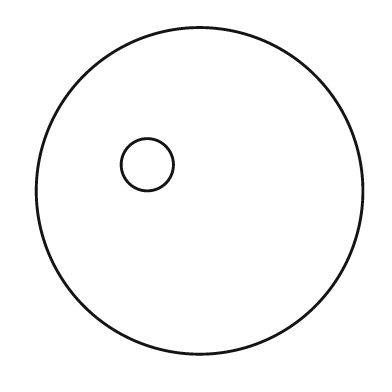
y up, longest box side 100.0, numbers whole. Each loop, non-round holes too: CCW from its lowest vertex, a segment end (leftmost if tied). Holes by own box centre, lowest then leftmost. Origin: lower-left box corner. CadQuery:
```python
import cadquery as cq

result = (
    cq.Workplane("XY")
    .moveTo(50.0, 50.0)
    .circle(50.0)
    .moveTo(34.0, 58.0)
    .circle(8.0)
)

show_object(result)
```